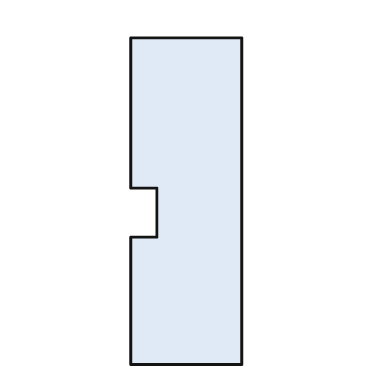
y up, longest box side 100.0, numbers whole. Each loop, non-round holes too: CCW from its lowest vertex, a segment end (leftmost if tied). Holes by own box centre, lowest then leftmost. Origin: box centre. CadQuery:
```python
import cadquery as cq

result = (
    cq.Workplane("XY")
    .moveTo(-17.0, -50.0)
    .lineTo(17.0, -50.0)
    .lineTo(17.0, 50.0)
    .lineTo(-17.0, 50.0)
    .lineTo(-17.0, 4.0)
    .lineTo(-9.0, 4.0)
    .lineTo(-9.0, -11.0)
    .lineTo(-17.0, -11.0)
    .close()
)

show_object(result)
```